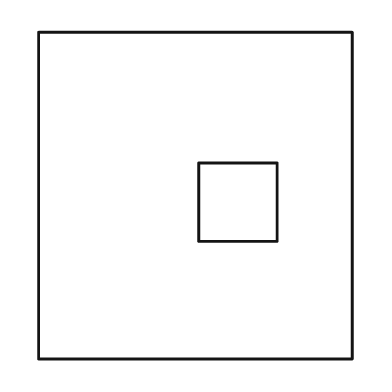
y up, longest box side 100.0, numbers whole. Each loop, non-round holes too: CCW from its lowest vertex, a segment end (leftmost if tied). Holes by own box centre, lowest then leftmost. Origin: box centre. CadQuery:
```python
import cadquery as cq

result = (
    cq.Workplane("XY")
    .moveTo(-48.0, -50.0)
    .lineTo(48.0, -50.0)
    .lineTo(48.0, 50.0)
    .lineTo(-48.0, 50.0)
    .close()
    .moveTo(1.0, -14.0)
    .lineTo(25.0, -14.0)
    .lineTo(25.0, 10.0)
    .lineTo(1.0, 10.0)
    .close()
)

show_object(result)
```